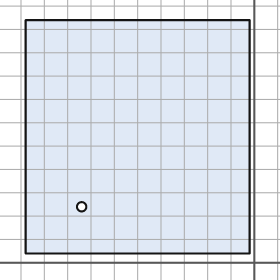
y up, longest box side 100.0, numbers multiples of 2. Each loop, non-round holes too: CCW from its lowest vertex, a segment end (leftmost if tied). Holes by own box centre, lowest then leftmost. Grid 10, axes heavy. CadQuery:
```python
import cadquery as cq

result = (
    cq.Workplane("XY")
    .moveTo(-98.0, 4.0)
    .lineTo(-2.0, 4.0)
    .lineTo(-2.0, 104.0)
    .lineTo(-98.0, 104.0)
    .close()
    .moveTo(-74.0, 24.0)
    .circle(2.0)
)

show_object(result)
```